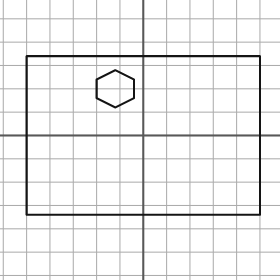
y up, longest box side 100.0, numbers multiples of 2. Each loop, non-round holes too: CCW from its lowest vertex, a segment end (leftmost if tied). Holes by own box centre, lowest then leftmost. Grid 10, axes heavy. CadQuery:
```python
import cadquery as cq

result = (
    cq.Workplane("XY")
    .moveTo(-50.0, -34.0)
    .lineTo(50.0, -34.0)
    .lineTo(50.0, 34.0)
    .lineTo(-50.0, 34.0)
    .close()
    .moveTo(-12.0, 12.0)
    .lineTo(-4.0, 16.0)
    .lineTo(-4.0, 24.0)
    .lineTo(-12.0, 28.0)
    .lineTo(-20.0, 24.0)
    .lineTo(-20.0, 16.0)
    .close()
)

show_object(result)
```